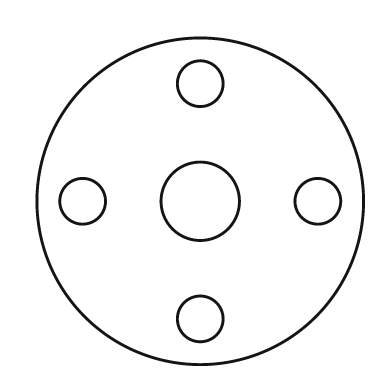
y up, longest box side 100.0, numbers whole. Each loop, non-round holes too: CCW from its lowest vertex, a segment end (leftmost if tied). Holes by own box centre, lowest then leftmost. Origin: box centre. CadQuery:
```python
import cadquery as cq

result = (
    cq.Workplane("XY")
    .moveTo(0.0, 0.0)
    .circle(50.0)
    .moveTo(0.0, -36.0)
    .circle(7.0)
    .moveTo(-36.0, 0.0)
    .circle(7.0)
    .moveTo(0.0, 0.0)
    .circle(12.0)
    .moveTo(36.0, 0.0)
    .circle(7.0)
    .moveTo(0.0, 36.0)
    .circle(7.0)
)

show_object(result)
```